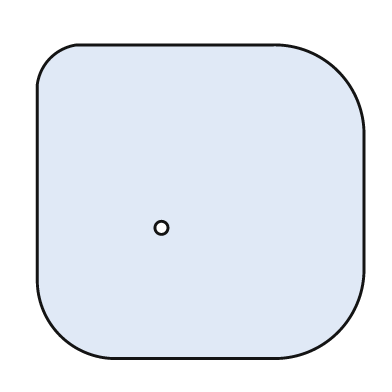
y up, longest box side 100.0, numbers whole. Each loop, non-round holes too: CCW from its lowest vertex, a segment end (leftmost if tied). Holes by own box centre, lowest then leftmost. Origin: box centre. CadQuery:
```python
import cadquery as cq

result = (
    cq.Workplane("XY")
    .moveTo(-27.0, -48.0)
    .lineTo(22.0, -48.0)
    .threePointArc((42.0, -40.0), (50.0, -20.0))
    .lineTo(50.0, 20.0)
    .threePointArc((42.0, 40.0), (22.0, 48.0))
    .lineTo(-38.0, 48.0)
    .threePointArc((-46.0, 44.0), (-50.0, 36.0))
    .lineTo(-50.0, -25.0)
    .threePointArc((-43.0, -41.0), (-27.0, -48.0))
    .close()
    .moveTo(-12.0, -8.0)
    .circle(2.0)
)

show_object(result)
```